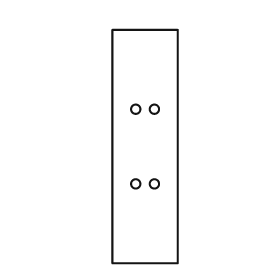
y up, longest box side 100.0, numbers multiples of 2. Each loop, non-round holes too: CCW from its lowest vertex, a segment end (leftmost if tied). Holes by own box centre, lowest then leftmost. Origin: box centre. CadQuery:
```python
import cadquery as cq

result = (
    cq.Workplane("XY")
    .moveTo(-14.0, -50.0)
    .lineTo(14.0, -50.0)
    .lineTo(14.0, 50.0)
    .lineTo(-14.0, 50.0)
    .close()
    .moveTo(-4.0, -16.0)
    .circle(2.0)
    .moveTo(4.0, -16.0)
    .circle(2.0)
    .moveTo(-4.0, 16.0)
    .circle(2.0)
    .moveTo(4.0, 16.0)
    .circle(2.0)
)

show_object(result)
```